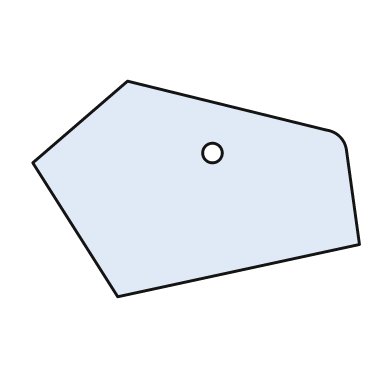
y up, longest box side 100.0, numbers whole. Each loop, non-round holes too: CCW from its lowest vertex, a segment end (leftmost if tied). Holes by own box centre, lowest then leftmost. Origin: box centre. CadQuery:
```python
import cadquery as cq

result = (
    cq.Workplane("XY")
    .moveTo(-24.0, -33.0)
    .lineTo(50.0, -17.0)
    .lineTo(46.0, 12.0)
    .threePointArc((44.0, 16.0), (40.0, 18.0))
    .lineTo(-21.0, 33.0)
    .lineTo(-50.0, 8.0)
    .close()
    .moveTo(5.0, 11.0)
    .circle(3.0)
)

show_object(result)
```